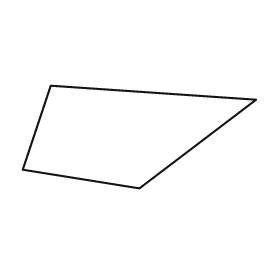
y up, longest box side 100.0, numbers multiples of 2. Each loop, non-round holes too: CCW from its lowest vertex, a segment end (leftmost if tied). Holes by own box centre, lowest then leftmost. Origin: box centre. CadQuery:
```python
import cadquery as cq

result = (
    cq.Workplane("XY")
    .moveTo(0.0, -22.0)
    .lineTo(50.0, 16.0)
    .lineTo(-38.0, 22.0)
    .lineTo(-50.0, -14.0)
    .close()
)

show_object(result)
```